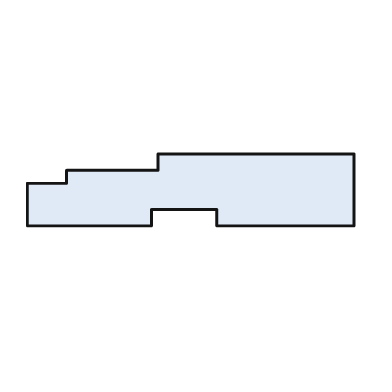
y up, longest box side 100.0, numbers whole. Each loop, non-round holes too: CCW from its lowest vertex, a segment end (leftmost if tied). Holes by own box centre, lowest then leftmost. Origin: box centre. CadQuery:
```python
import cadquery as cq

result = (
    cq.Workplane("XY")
    .moveTo(-50.0, -11.0)
    .lineTo(-12.0, -11.0)
    .lineTo(-12.0, -6.0)
    .lineTo(8.0, -6.0)
    .lineTo(8.0, -11.0)
    .lineTo(50.0, -11.0)
    .lineTo(50.0, 11.0)
    .lineTo(-10.0, 11.0)
    .lineTo(-10.0, 6.0)
    .lineTo(-38.0, 6.0)
    .lineTo(-38.0, 2.0)
    .lineTo(-50.0, 2.0)
    .close()
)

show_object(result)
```